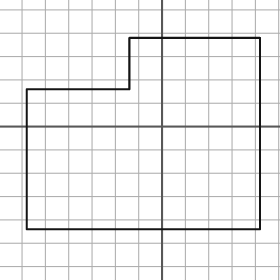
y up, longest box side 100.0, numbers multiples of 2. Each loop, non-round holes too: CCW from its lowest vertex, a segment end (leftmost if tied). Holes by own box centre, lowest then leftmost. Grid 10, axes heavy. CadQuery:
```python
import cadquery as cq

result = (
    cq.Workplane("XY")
    .moveTo(-58.0, -44.0)
    .lineTo(42.0, -44.0)
    .lineTo(42.0, 38.0)
    .lineTo(-14.0, 38.0)
    .lineTo(-14.0, 16.0)
    .lineTo(-58.0, 16.0)
    .close()
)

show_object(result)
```